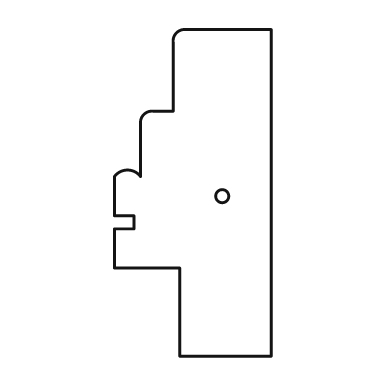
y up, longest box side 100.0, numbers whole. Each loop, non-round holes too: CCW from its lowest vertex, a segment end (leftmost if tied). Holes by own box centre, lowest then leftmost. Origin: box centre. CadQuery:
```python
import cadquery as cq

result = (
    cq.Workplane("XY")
    .moveTo(-4.0, -50.0)
    .lineTo(24.0, -50.0)
    .lineTo(24.0, 50.0)
    .lineTo(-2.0, 50.0)
    .threePointArc((-5.0, 49.0), (-6.0, 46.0))
    .lineTo(-6.0, 25.0)
    .lineTo(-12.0, 25.0)
    .threePointArc((-15.0, 24.0), (-16.0, 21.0))
    .lineTo(-16.0, 5.0)
    .threePointArc((-20.0, 7.0), (-24.0, 5.0))
    .lineTo(-24.0, -7.0)
    .lineTo(-18.0, -7.0)
    .lineTo(-18.0, -11.0)
    .lineTo(-24.0, -11.0)
    .lineTo(-24.0, -23.0)
    .lineTo(-4.0, -23.0)
    .close()
    .moveTo(9.0, -1.0)
    .circle(2.0)
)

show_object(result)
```